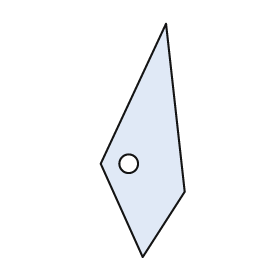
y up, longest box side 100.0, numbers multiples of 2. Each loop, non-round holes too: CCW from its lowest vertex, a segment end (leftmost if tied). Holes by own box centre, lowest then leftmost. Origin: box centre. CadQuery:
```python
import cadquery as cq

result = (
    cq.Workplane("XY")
    .moveTo(0.0, -50.0)
    .lineTo(18.0, -22.0)
    .lineTo(10.0, 50.0)
    .lineTo(-18.0, -10.0)
    .close()
    .moveTo(-6.0, -10.0)
    .circle(4.0)
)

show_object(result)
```